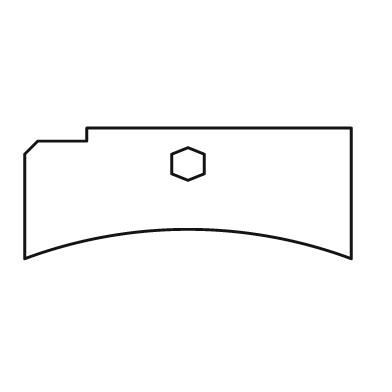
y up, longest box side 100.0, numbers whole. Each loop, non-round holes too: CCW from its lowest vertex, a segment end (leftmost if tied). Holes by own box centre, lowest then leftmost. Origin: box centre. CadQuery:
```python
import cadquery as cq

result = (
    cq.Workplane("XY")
    .moveTo(-50.0, -20.0)
    .threePointArc((0.0, -11.0), (50.0, -20.0))
    .lineTo(50.0, 20.0)
    .lineTo(-31.0, 20.0)
    .lineTo(-31.0, 16.0)
    .lineTo(-46.0, 16.0)
    .lineTo(-50.0, 12.0)
    .close()
    .moveTo(0.0, 4.0)
    .lineTo(5.0, 6.0)
    .lineTo(5.0, 12.0)
    .lineTo(0.0, 14.0)
    .lineTo(-5.0, 12.0)
    .lineTo(-5.0, 6.0)
    .close()
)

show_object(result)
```